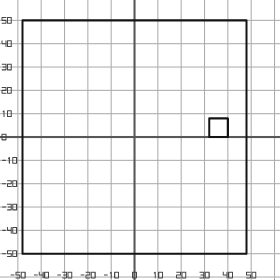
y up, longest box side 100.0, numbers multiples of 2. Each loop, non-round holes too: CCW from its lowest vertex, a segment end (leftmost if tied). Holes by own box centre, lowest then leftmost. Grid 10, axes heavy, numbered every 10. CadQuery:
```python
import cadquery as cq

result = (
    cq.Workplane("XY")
    .moveTo(-48.0, -50.0)
    .lineTo(48.0, -50.0)
    .lineTo(48.0, 50.0)
    .lineTo(-48.0, 50.0)
    .close()
    .moveTo(32.0, 0.0)
    .lineTo(40.0, 0.0)
    .lineTo(40.0, 8.0)
    .lineTo(32.0, 8.0)
    .close()
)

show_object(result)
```